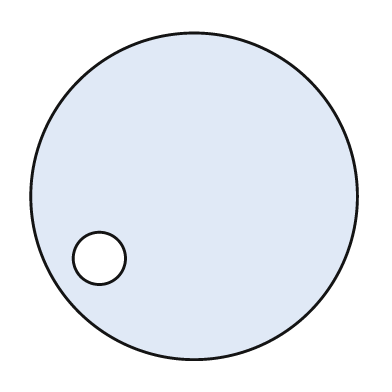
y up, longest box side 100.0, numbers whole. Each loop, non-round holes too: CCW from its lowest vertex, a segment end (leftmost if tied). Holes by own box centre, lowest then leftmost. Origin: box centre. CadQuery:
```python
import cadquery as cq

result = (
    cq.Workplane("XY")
    .moveTo(0.0, 0.0)
    .circle(50.0)
    .moveTo(-29.0, -19.0)
    .circle(8.0)
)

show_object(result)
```